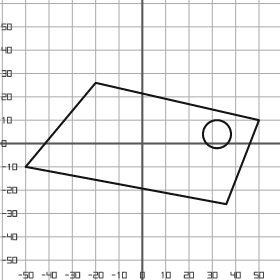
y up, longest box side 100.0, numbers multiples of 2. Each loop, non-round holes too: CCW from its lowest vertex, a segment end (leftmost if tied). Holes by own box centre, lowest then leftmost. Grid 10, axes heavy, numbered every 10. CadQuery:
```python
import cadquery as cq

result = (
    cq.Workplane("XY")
    .moveTo(36.0, -26.0)
    .lineTo(50.0, 10.0)
    .lineTo(-20.0, 26.0)
    .lineTo(-50.0, -10.0)
    .close()
    .moveTo(32.0, 4.0)
    .circle(6.0)
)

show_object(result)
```